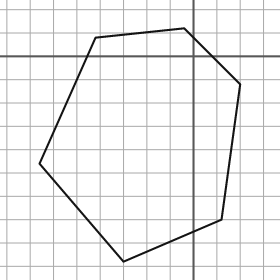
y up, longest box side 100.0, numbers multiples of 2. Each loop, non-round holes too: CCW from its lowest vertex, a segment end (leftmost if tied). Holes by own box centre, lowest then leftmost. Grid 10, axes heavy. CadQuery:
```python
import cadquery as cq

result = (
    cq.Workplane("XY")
    .moveTo(-30.0, -88.0)
    .lineTo(12.0, -70.0)
    .lineTo(20.0, -12.0)
    .lineTo(-4.0, 12.0)
    .lineTo(-42.0, 8.0)
    .lineTo(-66.0, -46.0)
    .close()
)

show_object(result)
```